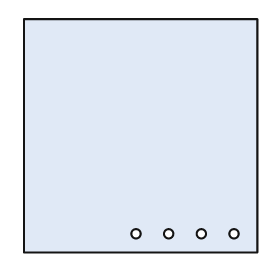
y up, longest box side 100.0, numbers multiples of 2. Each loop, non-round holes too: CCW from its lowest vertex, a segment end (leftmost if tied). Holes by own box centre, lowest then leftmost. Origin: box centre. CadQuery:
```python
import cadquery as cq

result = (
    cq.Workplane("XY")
    .moveTo(-50.0, -50.0)
    .lineTo(50.0, -50.0)
    .lineTo(50.0, 50.0)
    .lineTo(-50.0, 50.0)
    .close()
    .moveTo(-2.0, -42.0)
    .circle(2.0)
    .moveTo(12.0, -42.0)
    .circle(2.0)
    .moveTo(26.0, -42.0)
    .circle(2.0)
    .moveTo(40.0, -42.0)
    .circle(2.0)
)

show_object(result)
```